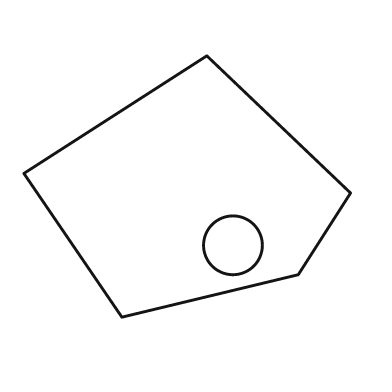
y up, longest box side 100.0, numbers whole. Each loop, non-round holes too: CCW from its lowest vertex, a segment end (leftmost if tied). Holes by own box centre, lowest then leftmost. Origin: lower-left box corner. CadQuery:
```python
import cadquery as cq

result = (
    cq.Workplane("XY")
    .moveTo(30.0, 0.0)
    .lineTo(84.0, 13.0)
    .lineTo(100.0, 38.0)
    .lineTo(56.0, 80.0)
    .lineTo(0.0, 44.0)
    .close()
    .moveTo(64.0, 22.0)
    .circle(9.0)
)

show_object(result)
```